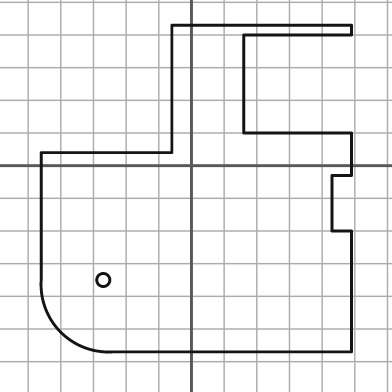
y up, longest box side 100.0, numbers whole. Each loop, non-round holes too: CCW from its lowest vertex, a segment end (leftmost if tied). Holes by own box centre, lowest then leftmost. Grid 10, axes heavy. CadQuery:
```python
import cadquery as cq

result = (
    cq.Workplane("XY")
    .moveTo(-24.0, -57.0)
    .lineTo(49.0, -57.0)
    .lineTo(49.0, -20.0)
    .lineTo(43.0, -20.0)
    .lineTo(43.0, -3.0)
    .lineTo(49.0, -3.0)
    .lineTo(49.0, 10.0)
    .lineTo(16.0, 10.0)
    .lineTo(16.0, 40.0)
    .lineTo(49.0, 40.0)
    .lineTo(49.0, 43.0)
    .lineTo(-6.0, 43.0)
    .lineTo(-6.0, 4.0)
    .lineTo(-46.0, 4.0)
    .lineTo(-46.0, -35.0)
    .threePointArc((-40.0, -51.0), (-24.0, -57.0))
    .close()
    .moveTo(-27.0, -35.0)
    .circle(2.0)
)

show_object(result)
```